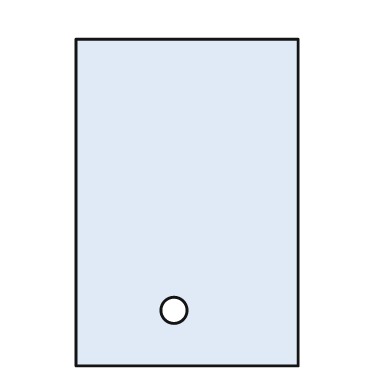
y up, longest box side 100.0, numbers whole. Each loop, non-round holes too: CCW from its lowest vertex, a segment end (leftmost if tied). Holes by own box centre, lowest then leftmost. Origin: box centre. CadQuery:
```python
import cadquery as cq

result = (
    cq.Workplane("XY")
    .moveTo(-34.0, -50.0)
    .lineTo(34.0, -50.0)
    .lineTo(34.0, 50.0)
    .lineTo(-34.0, 50.0)
    .close()
    .moveTo(-4.0, -33.0)
    .circle(4.0)
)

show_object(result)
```